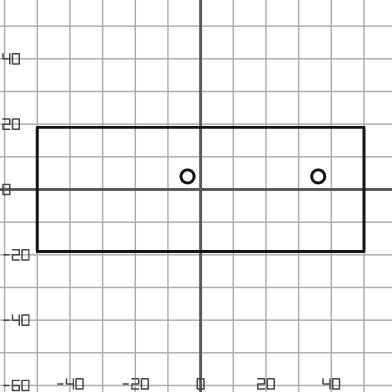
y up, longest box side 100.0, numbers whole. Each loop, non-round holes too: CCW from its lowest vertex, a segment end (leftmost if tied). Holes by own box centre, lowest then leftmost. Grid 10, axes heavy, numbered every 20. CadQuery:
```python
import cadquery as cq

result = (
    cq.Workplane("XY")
    .moveTo(-50.0, -19.0)
    .lineTo(50.0, -19.0)
    .lineTo(50.0, 19.0)
    .lineTo(-50.0, 19.0)
    .close()
    .moveTo(-4.0, 4.0)
    .circle(2.0)
    .moveTo(36.0, 4.0)
    .circle(2.0)
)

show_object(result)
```